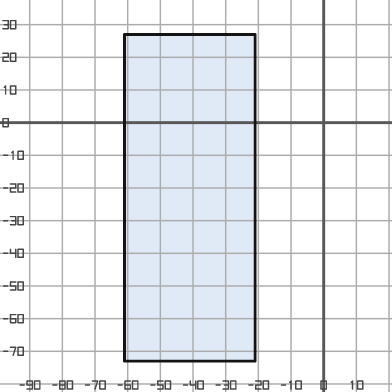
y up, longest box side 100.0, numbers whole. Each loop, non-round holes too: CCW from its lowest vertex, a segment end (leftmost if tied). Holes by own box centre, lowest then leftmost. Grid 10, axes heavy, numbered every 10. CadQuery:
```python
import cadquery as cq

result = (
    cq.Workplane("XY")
    .moveTo(-61.0, -73.0)
    .lineTo(-21.0, -73.0)
    .lineTo(-21.0, 27.0)
    .lineTo(-61.0, 27.0)
    .close()
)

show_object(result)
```